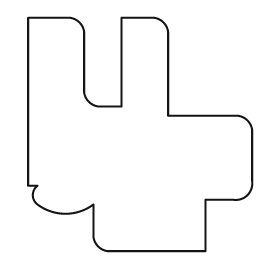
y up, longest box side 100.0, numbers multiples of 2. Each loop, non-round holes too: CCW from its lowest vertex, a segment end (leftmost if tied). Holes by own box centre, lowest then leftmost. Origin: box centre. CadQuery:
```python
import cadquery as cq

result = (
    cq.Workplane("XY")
    .moveTo(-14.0, -50.0)
    .lineTo(28.0, -50.0)
    .lineTo(28.0, -28.0)
    .lineTo(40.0, -28.0)
    .threePointArc((46.0, -26.0), (48.0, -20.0))
    .lineTo(48.0, 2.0)
    .threePointArc((46.0, 6.0), (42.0, 8.0))
    .lineTo(12.0, 8.0)
    .lineTo(12.0, 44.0)
    .threePointArc((10.0, 48.0), (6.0, 50.0))
    .lineTo(-8.0, 50.0)
    .lineTo(-8.0, 12.0)
    .lineTo(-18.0, 12.0)
    .threePointArc((-22.0, 14.0), (-24.0, 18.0))
    .lineTo(-24.0, 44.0)
    .threePointArc((-26.0, 48.0), (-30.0, 50.0))
    .lineTo(-48.0, 50.0)
    .lineTo(-48.0, -22.0)
    .lineTo(-44.0, -22.0)
    .threePointArc((-46.0, -26.0), (-44.0, -30.0))
    .threePointArc((-32.0, -34.0), (-20.0, -30.0))
    .lineTo(-20.0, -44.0)
    .threePointArc((-18.0, -48.0), (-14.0, -50.0))
    .close()
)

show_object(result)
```